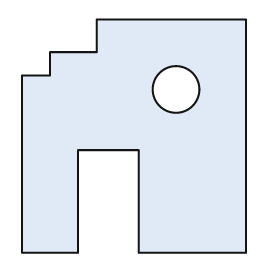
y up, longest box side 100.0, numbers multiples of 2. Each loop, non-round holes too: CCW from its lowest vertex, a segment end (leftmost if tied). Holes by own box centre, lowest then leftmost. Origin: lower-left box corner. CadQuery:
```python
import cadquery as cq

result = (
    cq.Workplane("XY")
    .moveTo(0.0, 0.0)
    .lineTo(24.0, 0.0)
    .lineTo(24.0, 44.0)
    .lineTo(50.0, 44.0)
    .lineTo(50.0, 0.0)
    .lineTo(96.0, 0.0)
    .lineTo(96.0, 100.0)
    .lineTo(32.0, 100.0)
    .lineTo(32.0, 86.0)
    .lineTo(12.0, 86.0)
    .lineTo(12.0, 76.0)
    .lineTo(0.0, 76.0)
    .close()
    .moveTo(66.0, 70.0)
    .circle(10.0)
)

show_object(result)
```